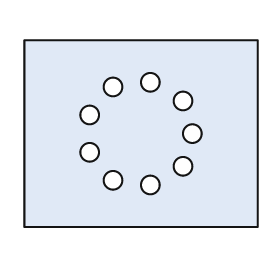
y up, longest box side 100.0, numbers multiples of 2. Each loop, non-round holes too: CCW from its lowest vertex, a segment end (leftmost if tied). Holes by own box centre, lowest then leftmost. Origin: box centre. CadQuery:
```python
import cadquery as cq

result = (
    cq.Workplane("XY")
    .moveTo(-50.0, -40.0)
    .lineTo(50.0, -40.0)
    .lineTo(50.0, 40.0)
    .lineTo(-50.0, 40.0)
    .close()
    .moveTo(4.0, -22.0)
    .circle(4.0)
    .moveTo(-12.0, -20.0)
    .circle(4.0)
    .moveTo(18.0, -14.0)
    .circle(4.0)
    .moveTo(-22.0, -8.0)
    .circle(4.0)
    .moveTo(22.0, 0.0)
    .circle(4.0)
    .moveTo(-22.0, 8.0)
    .circle(4.0)
    .moveTo(18.0, 14.0)
    .circle(4.0)
    .moveTo(-12.0, 20.0)
    .circle(4.0)
    .moveTo(4.0, 22.0)
    .circle(4.0)
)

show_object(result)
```